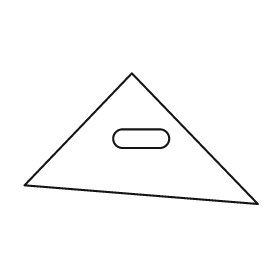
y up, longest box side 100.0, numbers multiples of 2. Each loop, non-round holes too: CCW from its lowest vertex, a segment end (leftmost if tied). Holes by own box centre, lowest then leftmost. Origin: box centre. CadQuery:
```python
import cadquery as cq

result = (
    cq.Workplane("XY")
    .moveTo(50.0, -28.0)
    .lineTo(-4.0, 28.0)
    .lineTo(-50.0, -20.0)
    .close()
    .moveTo(-8.0, -4.0)
    .lineTo(8.0, -4.0)
    .threePointArc((12.0, 0.0), (8.0, 4.0))
    .lineTo(-8.0, 4.0)
    .threePointArc((-12.0, 0.0), (-8.0, -4.0))
    .close()
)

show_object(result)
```